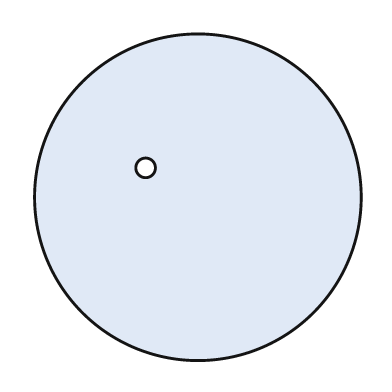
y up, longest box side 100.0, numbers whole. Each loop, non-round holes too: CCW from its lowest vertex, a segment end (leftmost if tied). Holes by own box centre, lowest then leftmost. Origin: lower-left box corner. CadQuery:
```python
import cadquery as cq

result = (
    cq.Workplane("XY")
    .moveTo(50.0, 50.0)
    .circle(50.0)
    .moveTo(34.0, 59.0)
    .circle(3.0)
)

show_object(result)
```